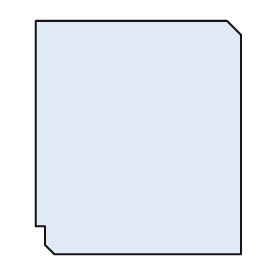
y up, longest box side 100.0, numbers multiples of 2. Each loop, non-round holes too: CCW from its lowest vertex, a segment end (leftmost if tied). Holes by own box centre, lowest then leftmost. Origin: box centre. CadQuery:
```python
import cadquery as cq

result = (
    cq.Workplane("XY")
    .moveTo(-36.0, -50.0)
    .lineTo(44.0, -50.0)
    .lineTo(44.0, 44.0)
    .lineTo(38.0, 50.0)
    .lineTo(-44.0, 50.0)
    .lineTo(-44.0, -38.0)
    .lineTo(-40.0, -38.0)
    .lineTo(-40.0, -46.0)
    .close()
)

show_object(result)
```